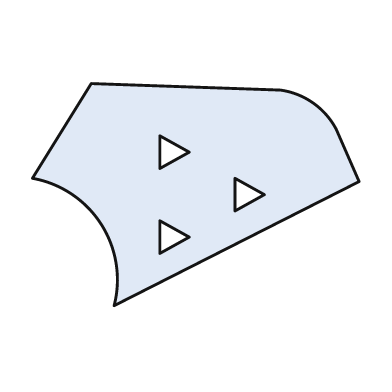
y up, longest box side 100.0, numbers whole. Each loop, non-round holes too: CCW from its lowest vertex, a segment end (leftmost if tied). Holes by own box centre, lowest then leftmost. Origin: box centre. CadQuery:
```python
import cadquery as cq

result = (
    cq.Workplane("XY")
    .moveTo(-25.0, -34.0)
    .lineTo(50.0, 4.0)
    .lineTo(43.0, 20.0)
    .threePointArc((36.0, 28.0), (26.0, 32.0))
    .lineTo(-32.0, 34.0)
    .lineTo(-50.0, 5.0)
    .threePointArc((-29.0, -9.0), (-25.0, -34.0))
    .close()
    .moveTo(-11.0, -18.0)
    .lineTo(-2.0, -13.0)
    .lineTo(-11.0, -8.0)
    .close()
    .moveTo(12.0, -5.0)
    .lineTo(21.0, 0.0)
    .lineTo(12.0, 5.0)
    .close()
    .moveTo(-11.0, 8.0)
    .lineTo(-2.0, 13.0)
    .lineTo(-11.0, 18.0)
    .close()
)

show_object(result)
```